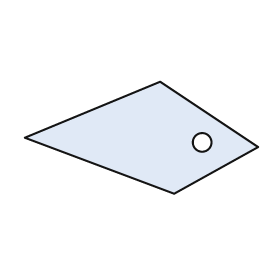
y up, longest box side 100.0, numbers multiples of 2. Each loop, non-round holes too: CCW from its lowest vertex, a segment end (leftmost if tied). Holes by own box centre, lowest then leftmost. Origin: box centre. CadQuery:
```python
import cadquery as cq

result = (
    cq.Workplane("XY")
    .moveTo(14.0, -24.0)
    .lineTo(50.0, -4.0)
    .lineTo(8.0, 24.0)
    .lineTo(-50.0, 0.0)
    .close()
    .moveTo(26.0, -2.0)
    .circle(4.0)
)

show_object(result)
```